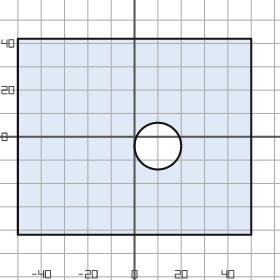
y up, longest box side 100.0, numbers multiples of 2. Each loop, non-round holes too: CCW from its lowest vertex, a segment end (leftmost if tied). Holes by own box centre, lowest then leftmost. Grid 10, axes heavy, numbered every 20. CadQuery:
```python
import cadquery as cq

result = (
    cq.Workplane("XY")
    .moveTo(-50.0, -42.0)
    .lineTo(50.0, -42.0)
    .lineTo(50.0, 42.0)
    .lineTo(-50.0, 42.0)
    .close()
    .moveTo(10.0, -4.0)
    .circle(10.0)
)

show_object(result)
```